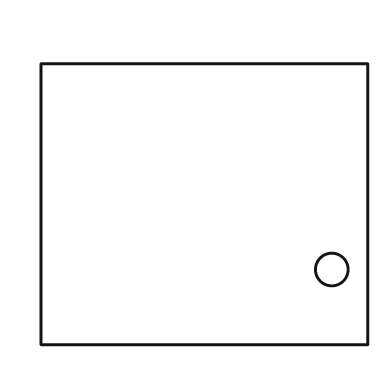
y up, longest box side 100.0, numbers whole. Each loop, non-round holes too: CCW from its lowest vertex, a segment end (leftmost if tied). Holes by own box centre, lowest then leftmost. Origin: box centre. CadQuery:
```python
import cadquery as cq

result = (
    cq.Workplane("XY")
    .moveTo(-50.0, -43.0)
    .lineTo(50.0, -43.0)
    .lineTo(50.0, 43.0)
    .lineTo(-50.0, 43.0)
    .close()
    .moveTo(39.0, -20.0)
    .circle(5.0)
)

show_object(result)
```